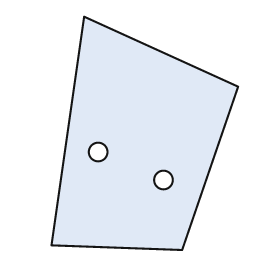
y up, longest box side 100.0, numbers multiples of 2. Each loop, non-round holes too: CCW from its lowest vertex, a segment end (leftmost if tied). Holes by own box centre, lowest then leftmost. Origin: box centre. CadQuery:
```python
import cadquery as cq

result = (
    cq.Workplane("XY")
    .moveTo(16.0, -50.0)
    .lineTo(40.0, 20.0)
    .lineTo(-26.0, 50.0)
    .lineTo(-40.0, -48.0)
    .close()
    .moveTo(8.0, -20.0)
    .circle(4.0)
    .moveTo(-20.0, -8.0)
    .circle(4.0)
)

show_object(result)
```